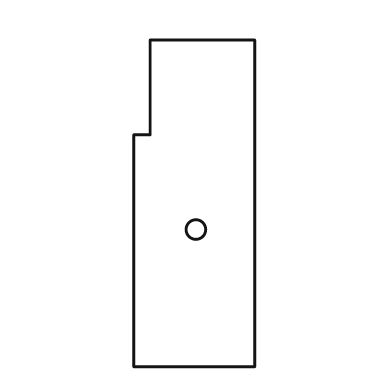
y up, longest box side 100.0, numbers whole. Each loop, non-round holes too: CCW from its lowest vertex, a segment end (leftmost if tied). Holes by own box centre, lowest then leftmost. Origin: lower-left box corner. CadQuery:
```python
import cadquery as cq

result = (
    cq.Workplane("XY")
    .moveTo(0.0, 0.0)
    .lineTo(37.0, 0.0)
    .lineTo(37.0, 100.0)
    .lineTo(5.0, 100.0)
    .lineTo(5.0, 71.0)
    .lineTo(0.0, 71.0)
    .close()
    .moveTo(19.0, 42.0)
    .circle(3.0)
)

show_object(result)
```